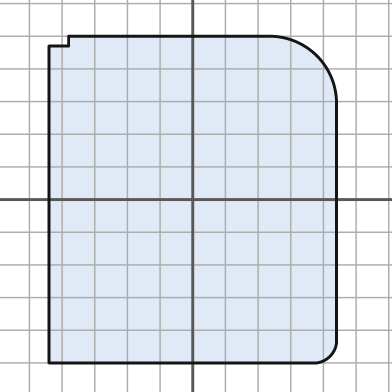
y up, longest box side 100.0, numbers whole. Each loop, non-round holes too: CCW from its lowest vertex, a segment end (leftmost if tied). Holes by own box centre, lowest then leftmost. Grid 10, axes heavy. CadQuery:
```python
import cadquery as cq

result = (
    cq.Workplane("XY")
    .moveTo(-44.0, -50.0)
    .lineTo(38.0, -50.0)
    .threePointArc((42.0, -48.0), (44.0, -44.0))
    .lineTo(44.0, 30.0)
    .threePointArc((38.0, 44.0), (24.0, 50.0))
    .lineTo(-38.0, 50.0)
    .lineTo(-38.0, 47.0)
    .lineTo(-44.0, 47.0)
    .close()
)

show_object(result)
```